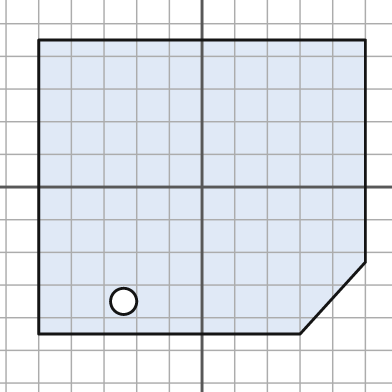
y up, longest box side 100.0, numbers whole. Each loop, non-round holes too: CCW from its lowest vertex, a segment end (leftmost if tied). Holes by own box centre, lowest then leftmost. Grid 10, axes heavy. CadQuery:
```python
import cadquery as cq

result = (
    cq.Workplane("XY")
    .moveTo(-50.0, -45.0)
    .lineTo(30.0, -45.0)
    .lineTo(50.0, -23.0)
    .lineTo(50.0, 45.0)
    .lineTo(-50.0, 45.0)
    .close()
    .moveTo(-24.0, -35.0)
    .circle(4.0)
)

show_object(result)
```